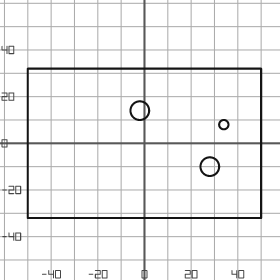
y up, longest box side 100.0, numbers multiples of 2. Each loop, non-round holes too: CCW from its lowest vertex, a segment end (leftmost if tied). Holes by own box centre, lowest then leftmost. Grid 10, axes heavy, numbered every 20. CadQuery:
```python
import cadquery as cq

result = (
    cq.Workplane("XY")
    .moveTo(-50.0, -32.0)
    .lineTo(50.0, -32.0)
    .lineTo(50.0, 32.0)
    .lineTo(-50.0, 32.0)
    .close()
    .moveTo(28.0, -10.0)
    .circle(4.0)
    .moveTo(34.0, 8.0)
    .circle(2.0)
    .moveTo(-2.0, 14.0)
    .circle(4.0)
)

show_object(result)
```